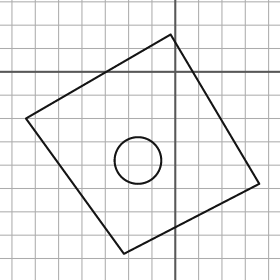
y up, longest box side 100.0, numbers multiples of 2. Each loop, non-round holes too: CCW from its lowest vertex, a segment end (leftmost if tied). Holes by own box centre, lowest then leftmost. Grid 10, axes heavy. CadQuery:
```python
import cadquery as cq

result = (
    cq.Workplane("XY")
    .moveTo(-22.0, -78.0)
    .lineTo(36.0, -48.0)
    .lineTo(-2.0, 16.0)
    .lineTo(-64.0, -20.0)
    .close()
    .moveTo(-16.0, -38.0)
    .circle(10.0)
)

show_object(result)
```